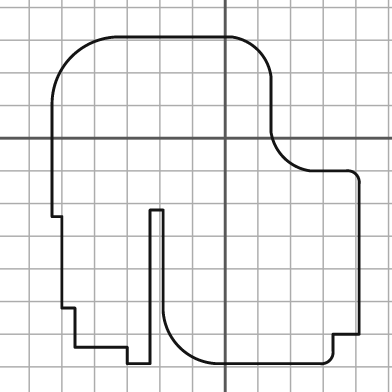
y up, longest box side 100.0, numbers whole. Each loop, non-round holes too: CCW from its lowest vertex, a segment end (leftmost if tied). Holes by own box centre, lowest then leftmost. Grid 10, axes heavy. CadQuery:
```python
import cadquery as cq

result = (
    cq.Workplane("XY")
    .moveTo(-30.0, -69.0)
    .lineTo(-23.0, -69.0)
    .lineTo(-23.0, -22.0)
    .lineTo(-19.0, -22.0)
    .lineTo(-19.0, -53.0)
    .threePointArc((-14.0, -64.0), (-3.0, -69.0))
    .lineTo(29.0, -69.0)
    .threePointArc((32.0, -68.0), (33.0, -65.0))
    .lineTo(33.0, -60.0)
    .lineTo(41.0, -60.0)
    .lineTo(41.0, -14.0)
    .threePointArc((40.0, -11.0), (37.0, -10.0))
    .lineTo(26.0, -10.0)
    .threePointArc((18.0, -6.0), (14.0, 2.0))
    .lineTo(14.0, 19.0)
    .threePointArc((10.0, 27.0), (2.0, 31.0))
    .lineTo(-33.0, 31.0)
    .threePointArc((-47.0, 25.0), (-53.0, 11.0))
    .lineTo(-53.0, -24.0)
    .lineTo(-50.0, -24.0)
    .lineTo(-50.0, -52.0)
    .lineTo(-46.0, -52.0)
    .lineTo(-46.0, -64.0)
    .lineTo(-30.0, -64.0)
    .close()
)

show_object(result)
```